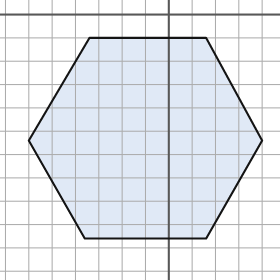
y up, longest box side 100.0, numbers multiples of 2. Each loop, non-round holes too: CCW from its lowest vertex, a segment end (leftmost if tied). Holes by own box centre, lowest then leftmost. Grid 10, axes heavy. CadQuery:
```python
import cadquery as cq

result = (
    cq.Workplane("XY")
    .moveTo(-36.0, -96.0)
    .lineTo(16.0, -96.0)
    .lineTo(40.0, -54.0)
    .lineTo(16.0, -10.0)
    .lineTo(-34.0, -10.0)
    .lineTo(-60.0, -54.0)
    .close()
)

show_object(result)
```